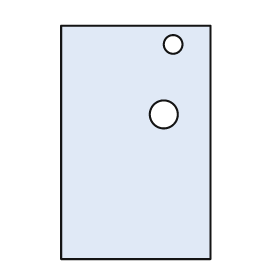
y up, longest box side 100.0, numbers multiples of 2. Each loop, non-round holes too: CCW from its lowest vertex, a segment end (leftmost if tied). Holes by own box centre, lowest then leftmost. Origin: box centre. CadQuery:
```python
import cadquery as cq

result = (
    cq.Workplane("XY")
    .moveTo(-32.0, -50.0)
    .lineTo(32.0, -50.0)
    .lineTo(32.0, 50.0)
    .lineTo(-32.0, 50.0)
    .close()
    .moveTo(12.0, 12.0)
    .circle(6.0)
    .moveTo(16.0, 42.0)
    .circle(4.0)
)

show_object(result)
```